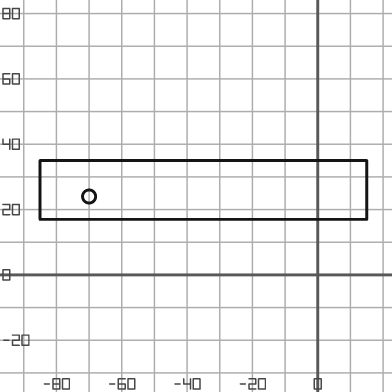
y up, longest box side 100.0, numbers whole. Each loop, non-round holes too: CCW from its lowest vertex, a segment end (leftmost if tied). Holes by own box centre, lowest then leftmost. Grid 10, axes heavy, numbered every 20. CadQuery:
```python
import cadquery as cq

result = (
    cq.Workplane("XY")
    .moveTo(-85.0, 17.0)
    .lineTo(15.0, 17.0)
    .lineTo(15.0, 35.0)
    .lineTo(-85.0, 35.0)
    .close()
    .moveTo(-70.0, 24.0)
    .circle(2.0)
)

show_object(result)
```